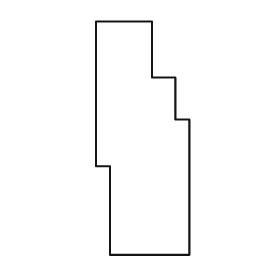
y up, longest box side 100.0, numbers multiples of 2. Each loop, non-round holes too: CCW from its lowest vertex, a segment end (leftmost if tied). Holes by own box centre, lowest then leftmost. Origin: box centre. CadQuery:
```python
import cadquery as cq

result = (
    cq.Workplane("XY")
    .moveTo(-14.0, -50.0)
    .lineTo(20.0, -50.0)
    .lineTo(20.0, 8.0)
    .lineTo(14.0, 8.0)
    .lineTo(14.0, 26.0)
    .lineTo(4.0, 26.0)
    .lineTo(4.0, 50.0)
    .lineTo(-20.0, 50.0)
    .lineTo(-20.0, -12.0)
    .lineTo(-14.0, -12.0)
    .close()
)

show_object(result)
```